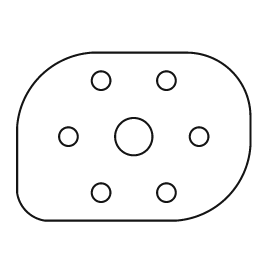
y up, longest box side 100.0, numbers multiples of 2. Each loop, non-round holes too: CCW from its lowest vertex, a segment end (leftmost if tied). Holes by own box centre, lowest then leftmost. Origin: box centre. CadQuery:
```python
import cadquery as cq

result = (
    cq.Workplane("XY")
    .moveTo(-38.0, -36.0)
    .lineTo(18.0, -36.0)
    .threePointArc((40.0, -26.0), (50.0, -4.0))
    .lineTo(50.0, 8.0)
    .threePointArc((42.0, 28.0), (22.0, 36.0))
    .lineTo(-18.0, 36.0)
    .threePointArc((-40.0, 26.0), (-50.0, 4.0))
    .lineTo(-50.0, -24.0)
    .threePointArc((-46.0, -32.0), (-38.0, -36.0))
    .close()
    .moveTo(-14.0, -24.0)
    .circle(4.0)
    .moveTo(14.0, -24.0)
    .circle(4.0)
    .moveTo(-28.0, 0.0)
    .circle(4.0)
    .moveTo(0.0, 0.0)
    .circle(8.0)
    .moveTo(28.0, 0.0)
    .circle(4.0)
    .moveTo(-14.0, 24.0)
    .circle(4.0)
    .moveTo(14.0, 24.0)
    .circle(4.0)
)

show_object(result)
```